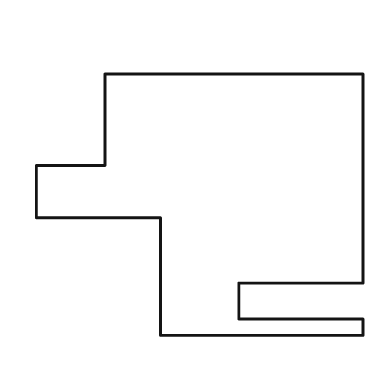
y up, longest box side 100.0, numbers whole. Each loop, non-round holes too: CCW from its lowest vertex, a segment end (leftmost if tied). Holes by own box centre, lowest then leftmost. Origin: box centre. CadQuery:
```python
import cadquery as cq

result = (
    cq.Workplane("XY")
    .moveTo(-12.0, -40.0)
    .lineTo(50.0, -40.0)
    .lineTo(50.0, -35.0)
    .lineTo(12.0, -35.0)
    .lineTo(12.0, -24.0)
    .lineTo(50.0, -24.0)
    .lineTo(50.0, 40.0)
    .lineTo(-29.0, 40.0)
    .lineTo(-29.0, 12.0)
    .lineTo(-50.0, 12.0)
    .lineTo(-50.0, -4.0)
    .lineTo(-12.0, -4.0)
    .close()
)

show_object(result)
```